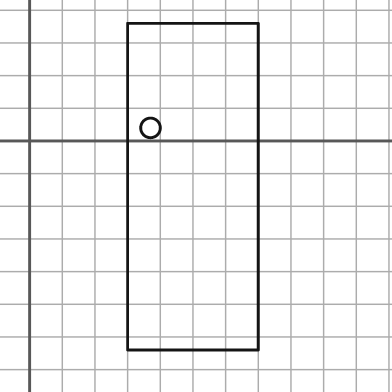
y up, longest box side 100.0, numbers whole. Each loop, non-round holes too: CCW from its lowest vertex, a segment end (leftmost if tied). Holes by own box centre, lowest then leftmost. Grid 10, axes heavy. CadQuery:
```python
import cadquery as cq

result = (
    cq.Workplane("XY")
    .moveTo(30.0, -64.0)
    .lineTo(70.0, -64.0)
    .lineTo(70.0, 36.0)
    .lineTo(30.0, 36.0)
    .close()
    .moveTo(37.0, 4.0)
    .circle(3.0)
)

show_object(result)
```